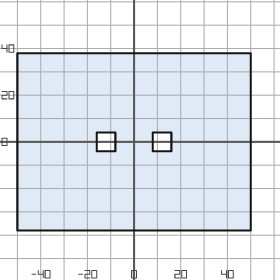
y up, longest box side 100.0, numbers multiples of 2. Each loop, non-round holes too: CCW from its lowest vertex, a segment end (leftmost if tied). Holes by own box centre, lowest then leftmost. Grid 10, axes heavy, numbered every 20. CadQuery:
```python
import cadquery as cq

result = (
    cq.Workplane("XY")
    .moveTo(-50.0, -38.0)
    .lineTo(50.0, -38.0)
    .lineTo(50.0, 38.0)
    .lineTo(-50.0, 38.0)
    .close()
    .moveTo(-16.0, -4.0)
    .lineTo(-8.0, -4.0)
    .lineTo(-8.0, 4.0)
    .lineTo(-16.0, 4.0)
    .close()
    .moveTo(8.0, -4.0)
    .lineTo(16.0, -4.0)
    .lineTo(16.0, 4.0)
    .lineTo(8.0, 4.0)
    .close()
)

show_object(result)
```